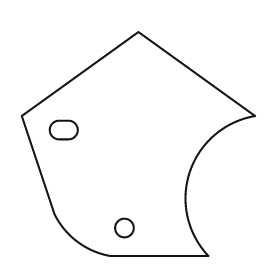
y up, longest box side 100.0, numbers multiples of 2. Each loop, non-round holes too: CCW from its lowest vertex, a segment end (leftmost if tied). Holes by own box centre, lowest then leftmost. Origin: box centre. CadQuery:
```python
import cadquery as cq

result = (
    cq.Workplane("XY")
    .moveTo(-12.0, -48.0)
    .lineTo(30.0, -48.0)
    .threePointArc((22.0, -12.0), (50.0, 12.0))
    .lineTo(0.0, 48.0)
    .lineTo(-50.0, 12.0)
    .lineTo(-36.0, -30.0)
    .threePointArc((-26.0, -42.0), (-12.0, -48.0))
    .close()
    .moveTo(-6.0, -36.0)
    .circle(4.0)
    .moveTo(-34.0, 2.0)
    .lineTo(-30.0, 2.0)
    .threePointArc((-26.0, 6.0), (-30.0, 10.0))
    .lineTo(-34.0, 10.0)
    .threePointArc((-38.0, 6.0), (-34.0, 2.0))
    .close()
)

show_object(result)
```